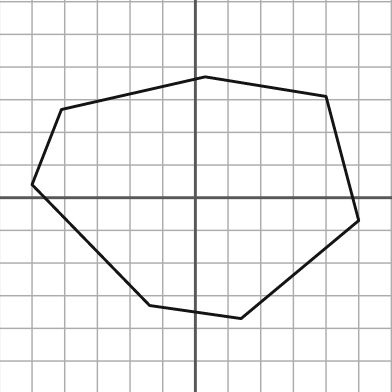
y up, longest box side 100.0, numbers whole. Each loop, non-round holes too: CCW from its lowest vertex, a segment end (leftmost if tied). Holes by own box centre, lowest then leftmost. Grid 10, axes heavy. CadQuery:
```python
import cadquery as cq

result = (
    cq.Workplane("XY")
    .moveTo(14.0, -37.0)
    .lineTo(50.0, -7.0)
    .lineTo(40.0, 31.0)
    .lineTo(3.0, 37.0)
    .lineTo(-41.0, 27.0)
    .lineTo(-50.0, 4.0)
    .lineTo(-14.0, -33.0)
    .close()
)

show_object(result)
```